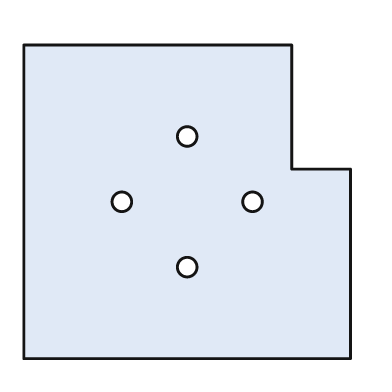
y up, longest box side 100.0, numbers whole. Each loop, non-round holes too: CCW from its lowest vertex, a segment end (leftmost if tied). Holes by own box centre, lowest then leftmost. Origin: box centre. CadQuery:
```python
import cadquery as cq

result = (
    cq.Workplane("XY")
    .moveTo(-50.0, -48.0)
    .lineTo(50.0, -48.0)
    .lineTo(50.0, 10.0)
    .lineTo(32.0, 10.0)
    .lineTo(32.0, 48.0)
    .lineTo(-50.0, 48.0)
    .close()
    .moveTo(0.0, -20.0)
    .circle(3.0)
    .moveTo(-20.0, 0.0)
    .circle(3.0)
    .moveTo(20.0, 0.0)
    .circle(3.0)
    .moveTo(0.0, 20.0)
    .circle(3.0)
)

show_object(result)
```